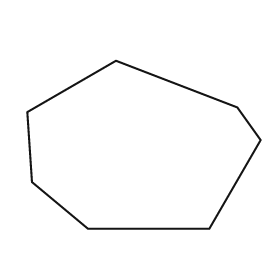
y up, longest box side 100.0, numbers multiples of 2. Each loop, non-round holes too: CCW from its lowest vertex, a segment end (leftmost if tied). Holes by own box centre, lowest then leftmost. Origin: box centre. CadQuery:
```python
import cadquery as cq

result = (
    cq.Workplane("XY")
    .moveTo(-24.0, -36.0)
    .lineTo(28.0, -36.0)
    .lineTo(50.0, 2.0)
    .lineTo(40.0, 16.0)
    .lineTo(-12.0, 36.0)
    .lineTo(-50.0, 14.0)
    .lineTo(-48.0, -16.0)
    .close()
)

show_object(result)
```